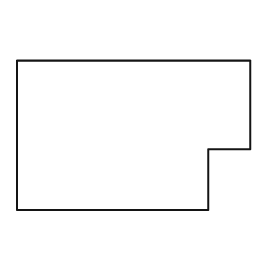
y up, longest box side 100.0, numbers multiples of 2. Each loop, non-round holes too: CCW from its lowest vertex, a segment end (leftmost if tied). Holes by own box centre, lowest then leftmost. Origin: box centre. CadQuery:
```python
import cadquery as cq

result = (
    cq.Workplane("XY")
    .moveTo(-50.0, -32.0)
    .lineTo(32.0, -32.0)
    .lineTo(32.0, -6.0)
    .lineTo(50.0, -6.0)
    .lineTo(50.0, 32.0)
    .lineTo(-50.0, 32.0)
    .close()
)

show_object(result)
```